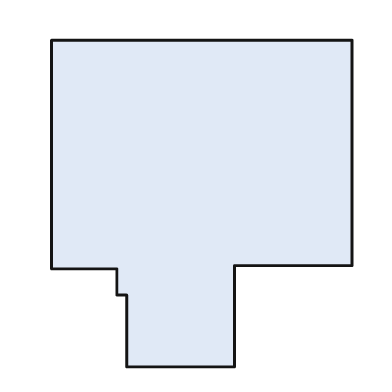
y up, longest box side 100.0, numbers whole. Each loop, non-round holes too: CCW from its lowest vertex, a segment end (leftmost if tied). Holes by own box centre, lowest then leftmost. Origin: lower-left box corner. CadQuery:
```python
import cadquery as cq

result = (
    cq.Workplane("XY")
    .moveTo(23.0, 0.0)
    .lineTo(56.0, 0.0)
    .lineTo(56.0, 31.0)
    .lineTo(92.0, 31.0)
    .lineTo(92.0, 100.0)
    .lineTo(0.0, 100.0)
    .lineTo(0.0, 30.0)
    .lineTo(20.0, 30.0)
    .lineTo(20.0, 22.0)
    .lineTo(23.0, 22.0)
    .close()
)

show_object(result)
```